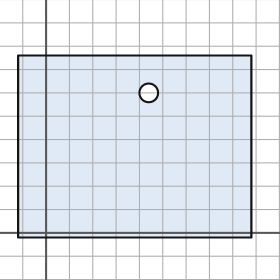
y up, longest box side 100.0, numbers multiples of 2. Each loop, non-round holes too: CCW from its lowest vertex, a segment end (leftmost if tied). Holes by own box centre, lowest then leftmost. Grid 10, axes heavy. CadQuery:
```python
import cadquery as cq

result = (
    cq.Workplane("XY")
    .moveTo(-12.0, -2.0)
    .lineTo(88.0, -2.0)
    .lineTo(88.0, 76.0)
    .lineTo(-12.0, 76.0)
    .close()
    .moveTo(44.0, 60.0)
    .circle(4.0)
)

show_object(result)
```